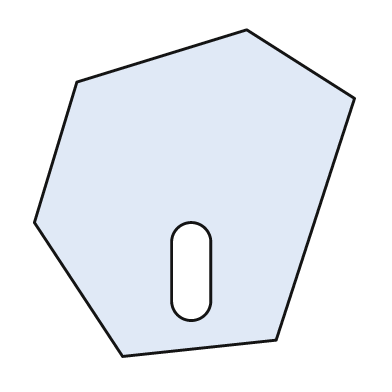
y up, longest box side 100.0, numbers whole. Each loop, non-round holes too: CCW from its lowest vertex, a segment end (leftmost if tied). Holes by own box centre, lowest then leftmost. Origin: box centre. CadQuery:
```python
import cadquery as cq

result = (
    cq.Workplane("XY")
    .moveTo(-22.0, -50.0)
    .lineTo(25.0, -45.0)
    .lineTo(49.0, 29.0)
    .lineTo(16.0, 50.0)
    .lineTo(-36.0, 34.0)
    .lineTo(-49.0, -9.0)
    .close()
    .moveTo(-7.0, -33.0)
    .threePointArc((-1.0, -39.0), (5.0, -33.0))
    .lineTo(5.0, -15.0)
    .threePointArc((-1.0, -9.0), (-7.0, -15.0))
    .close()
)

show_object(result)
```